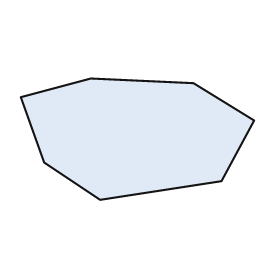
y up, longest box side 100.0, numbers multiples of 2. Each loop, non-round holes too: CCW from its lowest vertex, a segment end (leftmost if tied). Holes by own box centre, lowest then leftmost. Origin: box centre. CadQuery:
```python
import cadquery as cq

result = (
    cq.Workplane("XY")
    .moveTo(-16.0, -26.0)
    .lineTo(36.0, -18.0)
    .lineTo(50.0, 8.0)
    .lineTo(24.0, 24.0)
    .lineTo(-20.0, 26.0)
    .lineTo(-50.0, 18.0)
    .lineTo(-40.0, -10.0)
    .close()
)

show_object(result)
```